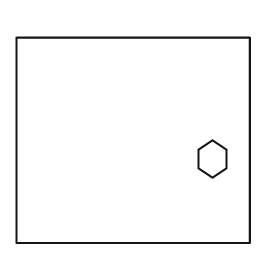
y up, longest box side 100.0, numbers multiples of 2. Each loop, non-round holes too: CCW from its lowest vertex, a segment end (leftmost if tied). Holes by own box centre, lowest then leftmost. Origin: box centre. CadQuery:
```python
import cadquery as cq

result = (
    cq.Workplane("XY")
    .moveTo(-50.0, -44.0)
    .lineTo(50.0, -44.0)
    .lineTo(50.0, 44.0)
    .lineTo(-50.0, 44.0)
    .close()
    .moveTo(34.0, -16.0)
    .lineTo(40.0, -12.0)
    .lineTo(40.0, -4.0)
    .lineTo(34.0, 0.0)
    .lineTo(28.0, -4.0)
    .lineTo(28.0, -12.0)
    .close()
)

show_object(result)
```